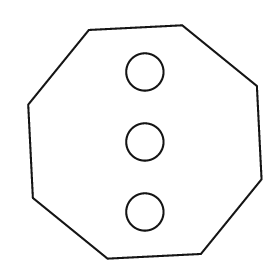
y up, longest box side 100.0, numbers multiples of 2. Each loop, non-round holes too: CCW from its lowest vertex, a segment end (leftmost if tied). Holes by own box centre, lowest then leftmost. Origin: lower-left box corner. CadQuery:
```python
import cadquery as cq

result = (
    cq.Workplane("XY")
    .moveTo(34.0, 0.0)
    .lineTo(74.0, 2.0)
    .lineTo(100.0, 34.0)
    .lineTo(98.0, 74.0)
    .lineTo(66.0, 100.0)
    .lineTo(26.0, 98.0)
    .lineTo(0.0, 66.0)
    .lineTo(2.0, 26.0)
    .close()
    .moveTo(50.0, 20.0)
    .circle(8.0)
    .moveTo(50.0, 50.0)
    .circle(8.0)
    .moveTo(50.0, 80.0)
    .circle(8.0)
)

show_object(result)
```